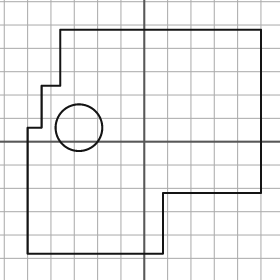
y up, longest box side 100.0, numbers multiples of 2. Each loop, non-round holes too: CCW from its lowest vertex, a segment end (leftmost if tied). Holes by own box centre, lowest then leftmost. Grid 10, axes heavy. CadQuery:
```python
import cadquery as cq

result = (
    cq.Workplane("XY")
    .moveTo(-50.0, -48.0)
    .lineTo(8.0, -48.0)
    .lineTo(8.0, -22.0)
    .lineTo(50.0, -22.0)
    .lineTo(50.0, 48.0)
    .lineTo(-36.0, 48.0)
    .lineTo(-36.0, 24.0)
    .lineTo(-44.0, 24.0)
    .lineTo(-44.0, 6.0)
    .lineTo(-50.0, 6.0)
    .close()
    .moveTo(-28.0, 6.0)
    .circle(10.0)
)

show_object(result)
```